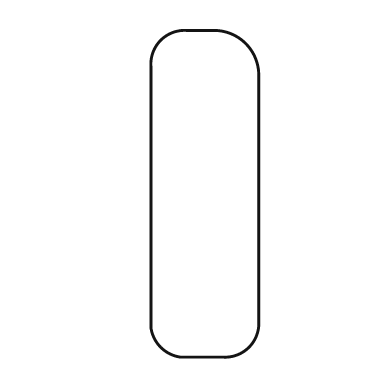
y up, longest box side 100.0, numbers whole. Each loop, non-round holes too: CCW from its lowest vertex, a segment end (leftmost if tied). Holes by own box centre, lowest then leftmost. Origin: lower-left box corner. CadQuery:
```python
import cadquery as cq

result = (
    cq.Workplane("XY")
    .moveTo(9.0, 0.0)
    .lineTo(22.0, 0.0)
    .threePointArc((30.0, 3.0), (33.0, 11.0))
    .lineTo(33.0, 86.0)
    .threePointArc((29.0, 96.0), (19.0, 100.0))
    .lineTo(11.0, 100.0)
    .threePointArc((3.0, 97.0), (0.0, 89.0))
    .lineTo(0.0, 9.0)
    .threePointArc((3.0, 3.0), (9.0, 0.0))
    .close()
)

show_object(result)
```